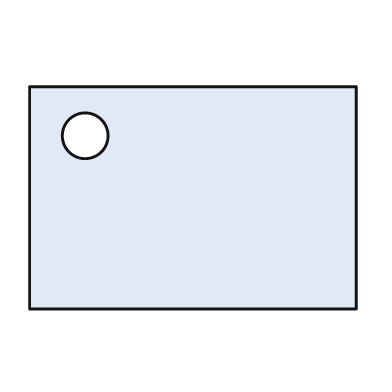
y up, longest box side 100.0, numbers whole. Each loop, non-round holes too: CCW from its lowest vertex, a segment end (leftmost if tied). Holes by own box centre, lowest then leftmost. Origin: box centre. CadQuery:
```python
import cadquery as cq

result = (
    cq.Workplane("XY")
    .moveTo(-50.0, -34.0)
    .lineTo(50.0, -34.0)
    .lineTo(50.0, 34.0)
    .lineTo(-50.0, 34.0)
    .close()
    .moveTo(-33.0, 19.0)
    .circle(7.0)
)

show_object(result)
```